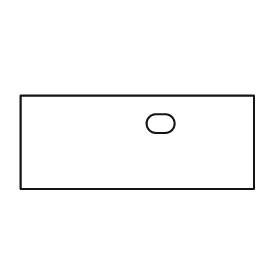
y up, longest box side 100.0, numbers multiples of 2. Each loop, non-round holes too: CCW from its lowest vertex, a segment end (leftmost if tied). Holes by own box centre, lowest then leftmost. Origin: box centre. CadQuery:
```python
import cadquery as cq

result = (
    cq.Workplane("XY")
    .moveTo(-50.0, -20.0)
    .lineTo(50.0, -20.0)
    .lineTo(50.0, 20.0)
    .lineTo(-50.0, 20.0)
    .close()
    .moveTo(8.0, 4.0)
    .lineTo(12.0, 4.0)
    .threePointArc((16.0, 8.0), (12.0, 12.0))
    .lineTo(8.0, 12.0)
    .threePointArc((4.0, 8.0), (8.0, 4.0))
    .close()
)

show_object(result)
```